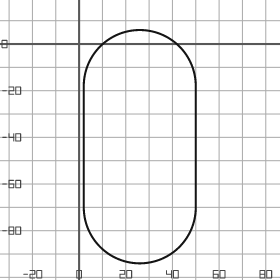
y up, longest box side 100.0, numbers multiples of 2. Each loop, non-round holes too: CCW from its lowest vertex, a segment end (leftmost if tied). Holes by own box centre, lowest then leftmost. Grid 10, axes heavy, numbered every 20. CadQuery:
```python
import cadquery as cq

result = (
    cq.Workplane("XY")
    .moveTo(2.0, -70.0)
    .threePointArc((26.0, -94.0), (50.0, -70.0))
    .lineTo(50.0, -18.0)
    .threePointArc((26.0, 6.0), (2.0, -18.0))
    .close()
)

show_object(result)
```